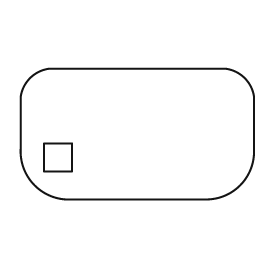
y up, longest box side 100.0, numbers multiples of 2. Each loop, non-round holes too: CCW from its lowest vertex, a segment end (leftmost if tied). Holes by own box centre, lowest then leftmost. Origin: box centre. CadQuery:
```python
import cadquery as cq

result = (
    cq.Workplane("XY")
    .moveTo(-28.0, -28.0)
    .lineTo(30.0, -28.0)
    .threePointArc((44.0, -22.0), (50.0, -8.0))
    .lineTo(50.0, 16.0)
    .threePointArc((46.0, 24.0), (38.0, 28.0))
    .lineTo(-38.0, 28.0)
    .threePointArc((-46.0, 24.0), (-50.0, 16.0))
    .lineTo(-50.0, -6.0)
    .threePointArc((-44.0, -22.0), (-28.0, -28.0))
    .close()
    .moveTo(-40.0, -16.0)
    .lineTo(-28.0, -16.0)
    .lineTo(-28.0, -4.0)
    .lineTo(-40.0, -4.0)
    .close()
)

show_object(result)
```